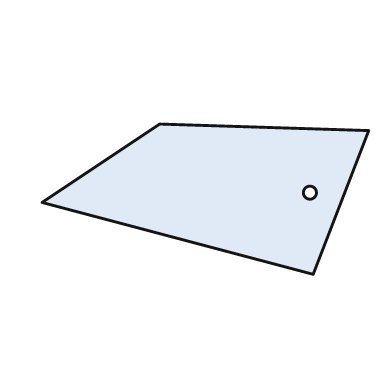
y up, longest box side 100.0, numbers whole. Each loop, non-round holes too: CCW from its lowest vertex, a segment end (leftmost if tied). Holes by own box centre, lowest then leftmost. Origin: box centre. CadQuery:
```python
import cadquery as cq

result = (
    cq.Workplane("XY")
    .moveTo(33.0, -23.0)
    .lineTo(50.0, 21.0)
    .lineTo(-14.0, 23.0)
    .lineTo(-50.0, -1.0)
    .close()
    .moveTo(32.0, 2.0)
    .circle(2.0)
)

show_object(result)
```